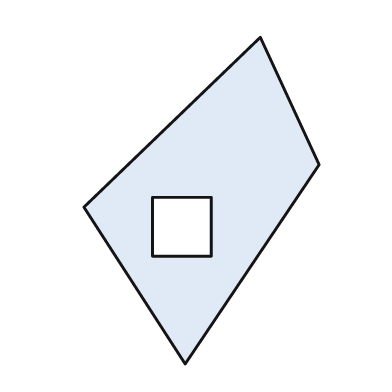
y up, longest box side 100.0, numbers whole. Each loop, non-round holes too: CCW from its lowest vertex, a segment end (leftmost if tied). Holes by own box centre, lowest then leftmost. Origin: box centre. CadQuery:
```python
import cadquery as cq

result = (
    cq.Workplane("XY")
    .moveTo(-5.0, -50.0)
    .lineTo(36.0, 11.0)
    .lineTo(18.0, 50.0)
    .lineTo(-36.0, -2.0)
    .close()
    .moveTo(-15.0, -17.0)
    .lineTo(3.0, -17.0)
    .lineTo(3.0, 1.0)
    .lineTo(-15.0, 1.0)
    .close()
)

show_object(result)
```